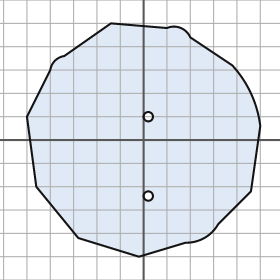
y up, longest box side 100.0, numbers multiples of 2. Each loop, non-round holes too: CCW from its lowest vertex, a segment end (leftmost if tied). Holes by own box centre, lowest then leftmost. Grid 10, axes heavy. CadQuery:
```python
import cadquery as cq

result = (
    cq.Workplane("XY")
    .moveTo(-2.0, -50.0)
    .lineTo(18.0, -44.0)
    .threePointArc((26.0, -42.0), (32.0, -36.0))
    .lineTo(46.0, -22.0)
    .lineTo(50.0, 6.0)
    .threePointArc((46.0, 20.0), (38.0, 32.0))
    .lineTo(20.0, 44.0)
    .threePointArc((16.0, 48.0), (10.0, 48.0))
    .lineTo(-14.0, 50.0)
    .lineTo(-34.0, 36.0)
    .threePointArc((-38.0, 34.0), (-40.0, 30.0))
    .lineTo(-50.0, 10.0)
    .lineTo(-46.0, -20.0)
    .lineTo(-28.0, -42.0)
    .close()
    .moveTo(2.0, -24.0)
    .circle(2.0)
    .moveTo(2.0, 10.0)
    .circle(2.0)
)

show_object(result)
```